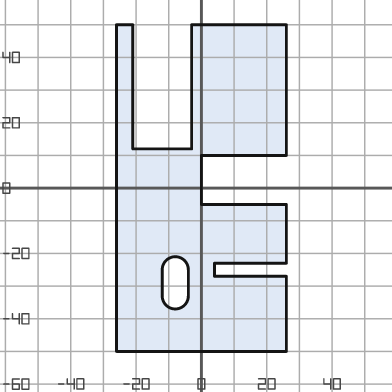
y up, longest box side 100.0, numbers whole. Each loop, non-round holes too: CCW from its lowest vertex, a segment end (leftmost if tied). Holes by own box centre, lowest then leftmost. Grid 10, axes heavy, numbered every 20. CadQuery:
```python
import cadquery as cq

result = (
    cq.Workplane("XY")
    .moveTo(-26.0, -50.0)
    .lineTo(26.0, -50.0)
    .lineTo(26.0, -27.0)
    .lineTo(4.0, -27.0)
    .lineTo(4.0, -23.0)
    .lineTo(26.0, -23.0)
    .lineTo(26.0, -5.0)
    .lineTo(0.0, -5.0)
    .lineTo(0.0, 10.0)
    .lineTo(26.0, 10.0)
    .lineTo(26.0, 50.0)
    .lineTo(-3.0, 50.0)
    .lineTo(-3.0, 12.0)
    .lineTo(-21.0, 12.0)
    .lineTo(-21.0, 50.0)
    .lineTo(-26.0, 50.0)
    .close()
    .moveTo(-12.0, -33.0)
    .threePointArc((-8.0, -37.0), (-4.0, -33.0))
    .lineTo(-4.0, -25.0)
    .threePointArc((-8.0, -21.0), (-12.0, -25.0))
    .close()
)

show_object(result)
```